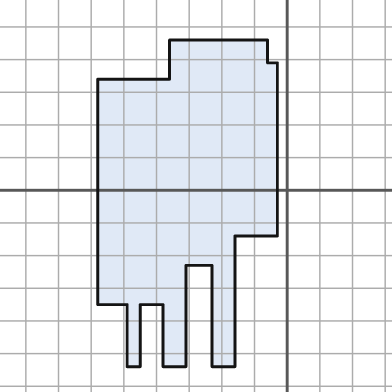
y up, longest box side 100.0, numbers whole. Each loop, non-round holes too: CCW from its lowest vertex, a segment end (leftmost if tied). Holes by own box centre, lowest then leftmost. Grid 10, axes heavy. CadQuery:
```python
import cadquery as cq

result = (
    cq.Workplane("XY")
    .moveTo(-49.0, -54.0)
    .lineTo(-45.0, -54.0)
    .lineTo(-45.0, -35.0)
    .lineTo(-38.0, -35.0)
    .lineTo(-38.0, -54.0)
    .lineTo(-31.0, -54.0)
    .lineTo(-31.0, -23.0)
    .lineTo(-23.0, -23.0)
    .lineTo(-23.0, -54.0)
    .lineTo(-16.0, -54.0)
    .lineTo(-16.0, -14.0)
    .lineTo(-3.0, -14.0)
    .lineTo(-3.0, 39.0)
    .lineTo(-6.0, 39.0)
    .lineTo(-6.0, 46.0)
    .lineTo(-36.0, 46.0)
    .lineTo(-36.0, 34.0)
    .lineTo(-58.0, 34.0)
    .lineTo(-58.0, -35.0)
    .lineTo(-49.0, -35.0)
    .close()
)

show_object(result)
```